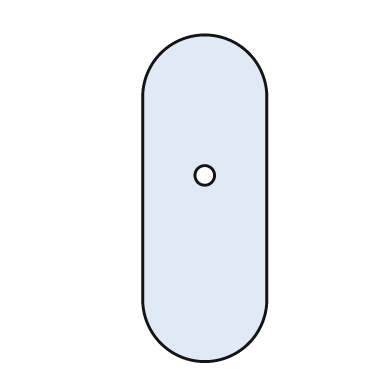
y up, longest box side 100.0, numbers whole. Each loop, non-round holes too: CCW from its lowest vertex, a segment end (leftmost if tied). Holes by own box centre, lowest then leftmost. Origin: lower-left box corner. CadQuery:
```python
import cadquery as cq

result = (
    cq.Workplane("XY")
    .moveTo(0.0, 19.0)
    .threePointArc((19.0, 0.0), (38.0, 19.0))
    .lineTo(38.0, 81.0)
    .threePointArc((19.0, 100.0), (0.0, 81.0))
    .close()
    .moveTo(19.0, 57.0)
    .circle(3.0)
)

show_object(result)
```